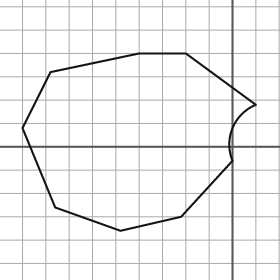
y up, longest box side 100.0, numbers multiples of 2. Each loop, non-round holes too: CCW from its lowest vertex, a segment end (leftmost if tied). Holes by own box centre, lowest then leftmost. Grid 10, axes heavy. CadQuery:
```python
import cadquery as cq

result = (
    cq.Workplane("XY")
    .moveTo(-48.0, -36.0)
    .lineTo(-22.0, -30.0)
    .lineTo(0.0, -6.0)
    .threePointArc((0.0, 8.0), (10.0, 18.0))
    .lineTo(-20.0, 40.0)
    .lineTo(-40.0, 40.0)
    .lineTo(-78.0, 32.0)
    .lineTo(-90.0, 8.0)
    .lineTo(-76.0, -26.0)
    .close()
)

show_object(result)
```